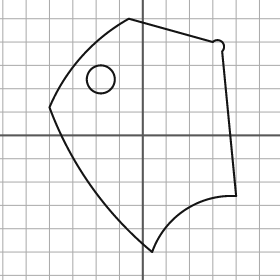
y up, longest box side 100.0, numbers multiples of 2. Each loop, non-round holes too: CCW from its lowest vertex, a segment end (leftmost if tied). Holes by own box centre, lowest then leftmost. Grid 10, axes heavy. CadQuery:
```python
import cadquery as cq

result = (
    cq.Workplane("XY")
    .moveTo(4.0, -50.0)
    .threePointArc((18.0, -32.0), (40.0, -26.0))
    .lineTo(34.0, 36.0)
    .threePointArc((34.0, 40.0), (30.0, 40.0))
    .lineTo(-6.0, 50.0)
    .threePointArc((-26.0, 34.0), (-40.0, 12.0))
    .threePointArc((-22.0, -22.0), (4.0, -50.0))
    .close()
    .moveTo(-18.0, 24.0)
    .circle(6.0)
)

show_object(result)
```